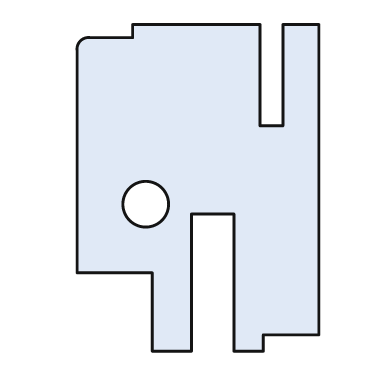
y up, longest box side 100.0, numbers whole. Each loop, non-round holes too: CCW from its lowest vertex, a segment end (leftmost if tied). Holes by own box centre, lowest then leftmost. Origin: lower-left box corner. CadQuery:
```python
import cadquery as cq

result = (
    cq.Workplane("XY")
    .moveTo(23.0, 0.0)
    .lineTo(35.0, 0.0)
    .lineTo(35.0, 42.0)
    .lineTo(48.0, 42.0)
    .lineTo(48.0, 0.0)
    .lineTo(57.0, 0.0)
    .lineTo(57.0, 5.0)
    .lineTo(74.0, 5.0)
    .lineTo(74.0, 100.0)
    .lineTo(63.0, 100.0)
    .lineTo(63.0, 69.0)
    .lineTo(56.0, 69.0)
    .lineTo(56.0, 100.0)
    .lineTo(17.0, 100.0)
    .lineTo(17.0, 96.0)
    .lineTo(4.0, 96.0)
    .threePointArc((1.0, 95.0), (0.0, 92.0))
    .lineTo(0.0, 24.0)
    .lineTo(23.0, 24.0)
    .close()
    .moveTo(21.0, 45.0)
    .circle(7.0)
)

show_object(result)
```